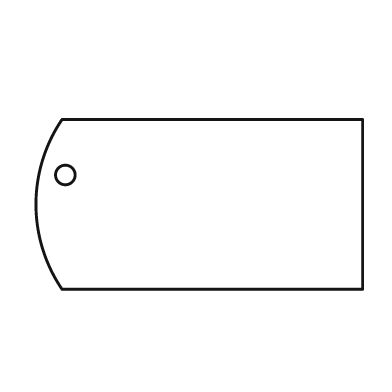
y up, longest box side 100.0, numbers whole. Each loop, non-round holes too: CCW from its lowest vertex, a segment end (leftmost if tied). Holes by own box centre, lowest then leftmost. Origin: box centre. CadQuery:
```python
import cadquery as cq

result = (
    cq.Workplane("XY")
    .moveTo(-42.0, -26.0)
    .lineTo(50.0, -26.0)
    .lineTo(50.0, 26.0)
    .lineTo(-42.0, 26.0)
    .threePointArc((-50.0, 0.0), (-42.0, -26.0))
    .close()
    .moveTo(-41.0, 9.0)
    .circle(3.0)
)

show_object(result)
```